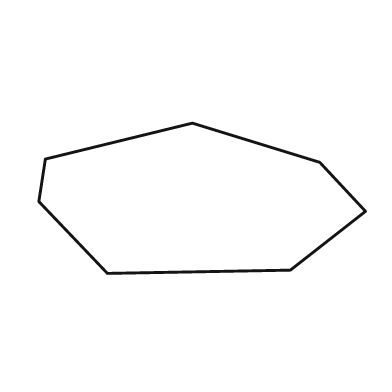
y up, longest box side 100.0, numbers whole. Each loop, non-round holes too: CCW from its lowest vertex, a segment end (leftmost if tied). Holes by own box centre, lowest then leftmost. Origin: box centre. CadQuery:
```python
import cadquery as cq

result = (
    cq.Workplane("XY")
    .moveTo(-29.0, -23.0)
    .lineTo(27.0, -22.0)
    .lineTo(50.0, -4.0)
    .lineTo(36.0, 11.0)
    .lineTo(-3.0, 23.0)
    .lineTo(-48.0, 12.0)
    .lineTo(-50.0, -1.0)
    .close()
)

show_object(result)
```